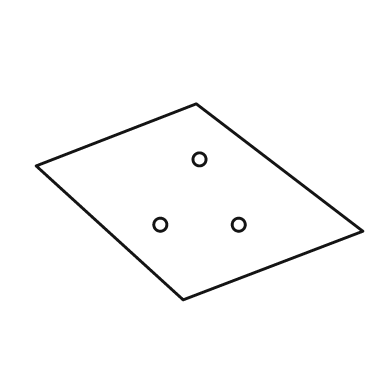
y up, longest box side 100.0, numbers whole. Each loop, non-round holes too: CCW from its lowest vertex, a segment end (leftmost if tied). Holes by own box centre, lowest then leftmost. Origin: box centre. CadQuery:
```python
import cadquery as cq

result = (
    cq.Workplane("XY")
    .moveTo(-5.0, -30.0)
    .lineTo(50.0, -9.0)
    .lineTo(-1.0, 30.0)
    .lineTo(-50.0, 11.0)
    .close()
    .moveTo(-12.0, -7.0)
    .circle(2.0)
    .moveTo(12.0, -7.0)
    .circle(2.0)
    .moveTo(0.0, 13.0)
    .circle(2.0)
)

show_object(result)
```